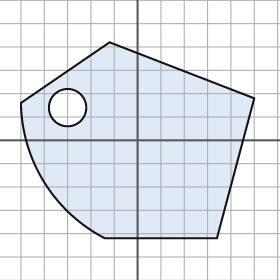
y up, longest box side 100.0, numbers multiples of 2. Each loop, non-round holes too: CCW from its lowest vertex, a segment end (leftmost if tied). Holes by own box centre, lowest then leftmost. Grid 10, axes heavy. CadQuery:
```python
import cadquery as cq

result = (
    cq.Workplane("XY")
    .moveTo(-14.0, -42.0)
    .lineTo(34.0, -42.0)
    .lineTo(50.0, 18.0)
    .lineTo(-12.0, 42.0)
    .lineTo(-50.0, 16.0)
    .threePointArc((-40.0, -18.0), (-14.0, -42.0))
    .close()
    .moveTo(-30.0, 14.0)
    .circle(8.0)
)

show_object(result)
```